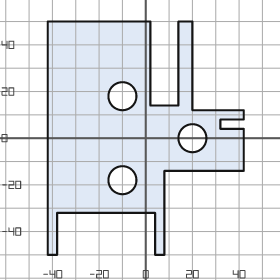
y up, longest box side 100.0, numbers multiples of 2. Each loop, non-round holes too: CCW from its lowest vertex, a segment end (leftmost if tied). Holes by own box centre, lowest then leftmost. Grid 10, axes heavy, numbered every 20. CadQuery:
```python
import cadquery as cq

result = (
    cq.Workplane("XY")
    .moveTo(-42.0, -50.0)
    .lineTo(-38.0, -50.0)
    .lineTo(-38.0, -32.0)
    .lineTo(4.0, -32.0)
    .lineTo(4.0, -50.0)
    .lineTo(8.0, -50.0)
    .lineTo(8.0, -14.0)
    .lineTo(42.0, -14.0)
    .lineTo(42.0, 4.0)
    .lineTo(32.0, 4.0)
    .lineTo(32.0, 8.0)
    .lineTo(42.0, 8.0)
    .lineTo(42.0, 12.0)
    .lineTo(20.0, 12.0)
    .lineTo(20.0, 50.0)
    .lineTo(14.0, 50.0)
    .lineTo(14.0, 14.0)
    .lineTo(2.0, 14.0)
    .lineTo(2.0, 50.0)
    .lineTo(-42.0, 50.0)
    .close()
    .moveTo(-10.0, -18.0)
    .circle(6.0)
    .moveTo(20.0, 0.0)
    .circle(6.0)
    .moveTo(-10.0, 18.0)
    .circle(6.0)
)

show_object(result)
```